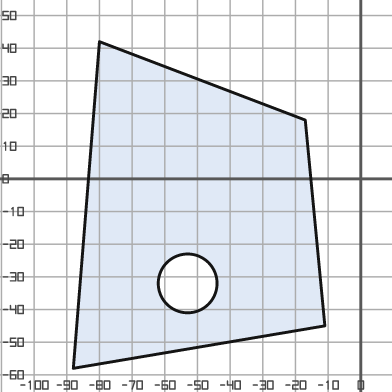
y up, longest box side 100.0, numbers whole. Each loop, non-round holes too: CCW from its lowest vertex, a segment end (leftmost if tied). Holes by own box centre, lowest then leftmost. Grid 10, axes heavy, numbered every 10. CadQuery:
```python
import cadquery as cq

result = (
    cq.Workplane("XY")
    .moveTo(-88.0, -58.0)
    .lineTo(-11.0, -45.0)
    .lineTo(-17.0, 18.0)
    .lineTo(-80.0, 42.0)
    .close()
    .moveTo(-53.0, -32.0)
    .circle(9.0)
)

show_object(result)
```